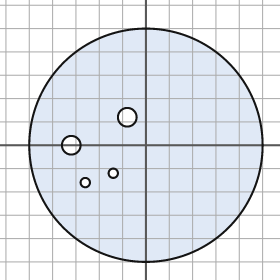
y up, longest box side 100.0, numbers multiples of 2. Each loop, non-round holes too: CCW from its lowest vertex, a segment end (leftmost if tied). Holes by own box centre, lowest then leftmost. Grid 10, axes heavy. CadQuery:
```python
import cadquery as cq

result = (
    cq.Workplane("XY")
    .moveTo(0.0, 0.0)
    .circle(50.0)
    .moveTo(-26.0, -16.0)
    .circle(2.0)
    .moveTo(-14.0, -12.0)
    .circle(2.0)
    .moveTo(-32.0, 0.0)
    .circle(4.0)
    .moveTo(-8.0, 12.0)
    .circle(4.0)
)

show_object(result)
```